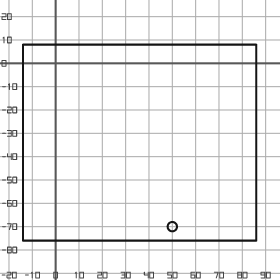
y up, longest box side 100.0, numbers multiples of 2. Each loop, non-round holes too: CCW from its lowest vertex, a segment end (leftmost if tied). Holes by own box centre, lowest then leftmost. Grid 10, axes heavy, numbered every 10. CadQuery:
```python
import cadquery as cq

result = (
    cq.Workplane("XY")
    .moveTo(-14.0, -76.0)
    .lineTo(86.0, -76.0)
    .lineTo(86.0, 8.0)
    .lineTo(-14.0, 8.0)
    .close()
    .moveTo(50.0, -70.0)
    .circle(2.0)
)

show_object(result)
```